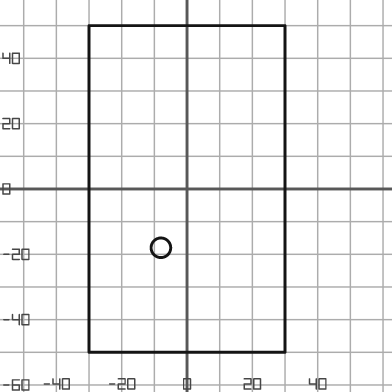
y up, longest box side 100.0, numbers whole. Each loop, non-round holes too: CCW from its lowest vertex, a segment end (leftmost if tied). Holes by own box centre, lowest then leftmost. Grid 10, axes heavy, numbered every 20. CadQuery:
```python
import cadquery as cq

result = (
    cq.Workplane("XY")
    .moveTo(-30.0, -50.0)
    .lineTo(30.0, -50.0)
    .lineTo(30.0, 50.0)
    .lineTo(-30.0, 50.0)
    .close()
    .moveTo(-8.0, -18.0)
    .circle(3.0)
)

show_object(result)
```